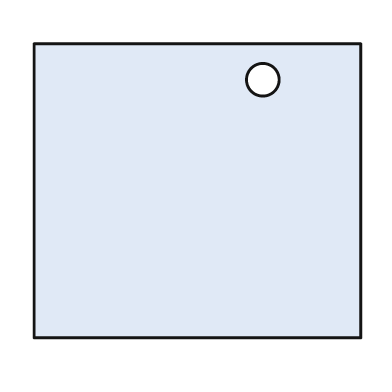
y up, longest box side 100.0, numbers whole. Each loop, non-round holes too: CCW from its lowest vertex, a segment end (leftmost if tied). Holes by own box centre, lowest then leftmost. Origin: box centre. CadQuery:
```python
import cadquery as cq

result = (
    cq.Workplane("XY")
    .moveTo(-50.0, -45.0)
    .lineTo(50.0, -45.0)
    .lineTo(50.0, 45.0)
    .lineTo(-50.0, 45.0)
    .close()
    .moveTo(20.0, 34.0)
    .circle(5.0)
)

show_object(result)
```